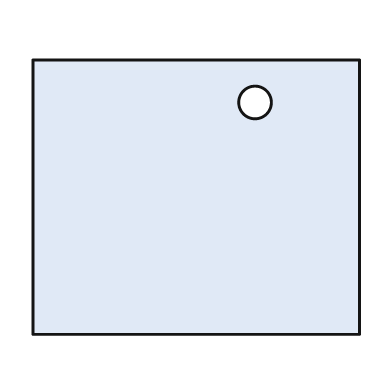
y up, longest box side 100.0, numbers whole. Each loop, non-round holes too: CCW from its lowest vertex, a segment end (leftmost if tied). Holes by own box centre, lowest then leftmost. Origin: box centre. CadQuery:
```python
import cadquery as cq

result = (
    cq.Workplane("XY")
    .moveTo(-50.0, -42.0)
    .lineTo(50.0, -42.0)
    .lineTo(50.0, 42.0)
    .lineTo(-50.0, 42.0)
    .close()
    .moveTo(18.0, 29.0)
    .circle(5.0)
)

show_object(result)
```